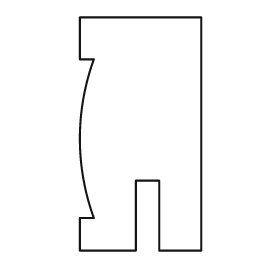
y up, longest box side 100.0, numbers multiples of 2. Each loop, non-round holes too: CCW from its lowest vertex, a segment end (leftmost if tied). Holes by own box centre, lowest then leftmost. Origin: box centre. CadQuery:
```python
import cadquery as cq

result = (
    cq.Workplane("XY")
    .moveTo(-26.0, -50.0)
    .lineTo(-2.0, -50.0)
    .lineTo(-2.0, -20.0)
    .lineTo(8.0, -20.0)
    .lineTo(8.0, -50.0)
    .lineTo(26.0, -50.0)
    .lineTo(26.0, 50.0)
    .lineTo(-26.0, 50.0)
    .lineTo(-26.0, 32.0)
    .lineTo(-20.0, 32.0)
    .threePointArc((-26.0, -2.0), (-20.0, -36.0))
    .lineTo(-26.0, -36.0)
    .close()
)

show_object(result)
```